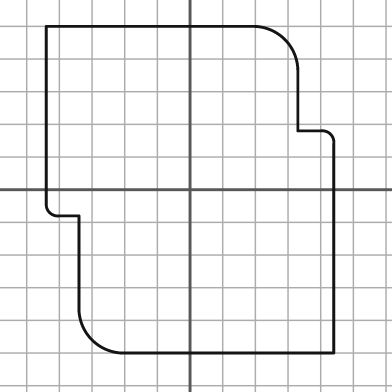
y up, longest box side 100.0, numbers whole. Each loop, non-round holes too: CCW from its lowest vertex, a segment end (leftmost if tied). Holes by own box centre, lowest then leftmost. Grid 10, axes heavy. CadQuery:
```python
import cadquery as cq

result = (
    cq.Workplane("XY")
    .moveTo(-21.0, -50.0)
    .lineTo(44.0, -50.0)
    .lineTo(44.0, 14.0)
    .threePointArc((43.0, 17.0), (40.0, 18.0))
    .lineTo(33.0, 18.0)
    .lineTo(33.0, 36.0)
    .threePointArc((29.0, 46.0), (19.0, 50.0))
    .lineTo(-44.0, 50.0)
    .lineTo(-44.0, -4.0)
    .threePointArc((-43.0, -7.0), (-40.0, -8.0))
    .lineTo(-34.0, -8.0)
    .lineTo(-34.0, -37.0)
    .threePointArc((-30.0, -46.0), (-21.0, -50.0))
    .close()
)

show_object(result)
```